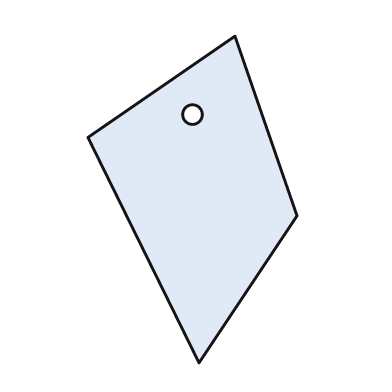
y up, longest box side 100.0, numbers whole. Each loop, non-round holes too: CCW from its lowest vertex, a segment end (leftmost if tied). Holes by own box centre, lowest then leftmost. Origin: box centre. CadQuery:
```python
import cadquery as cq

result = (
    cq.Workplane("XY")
    .moveTo(2.0, -50.0)
    .lineTo(32.0, -5.0)
    .lineTo(13.0, 50.0)
    .lineTo(-32.0, 19.0)
    .close()
    .moveTo(0.0, 26.0)
    .circle(3.0)
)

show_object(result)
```